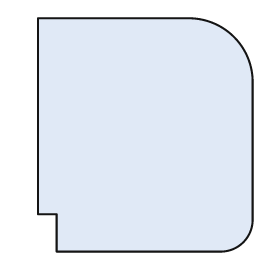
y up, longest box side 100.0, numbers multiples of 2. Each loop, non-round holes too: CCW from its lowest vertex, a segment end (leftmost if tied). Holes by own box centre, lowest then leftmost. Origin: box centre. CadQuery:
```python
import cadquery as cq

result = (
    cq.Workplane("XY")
    .moveTo(-38.0, -50.0)
    .lineTo(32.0, -50.0)
    .threePointArc((42.0, -46.0), (46.0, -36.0))
    .lineTo(46.0, 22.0)
    .threePointArc((38.0, 42.0), (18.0, 50.0))
    .lineTo(-46.0, 50.0)
    .lineTo(-46.0, -34.0)
    .lineTo(-38.0, -34.0)
    .close()
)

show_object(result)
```